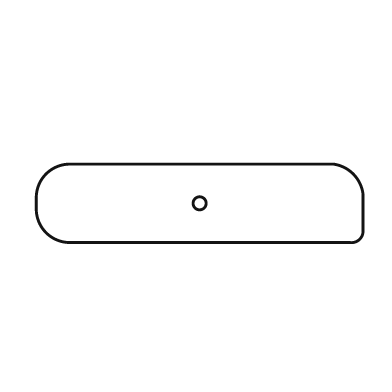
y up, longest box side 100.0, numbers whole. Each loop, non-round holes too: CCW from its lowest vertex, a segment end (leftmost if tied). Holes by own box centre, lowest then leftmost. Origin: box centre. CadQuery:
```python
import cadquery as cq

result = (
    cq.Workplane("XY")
    .moveTo(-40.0, -12.0)
    .lineTo(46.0, -12.0)
    .threePointArc((49.0, -11.0), (50.0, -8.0))
    .lineTo(50.0, 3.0)
    .threePointArc((47.0, 9.0), (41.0, 12.0))
    .lineTo(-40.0, 12.0)
    .threePointArc((-47.0, 9.0), (-50.0, 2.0))
    .lineTo(-50.0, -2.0)
    .threePointArc((-47.0, -9.0), (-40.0, -12.0))
    .close()
    .moveTo(0.0, 0.0)
    .circle(2.0)
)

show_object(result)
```